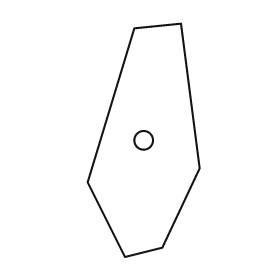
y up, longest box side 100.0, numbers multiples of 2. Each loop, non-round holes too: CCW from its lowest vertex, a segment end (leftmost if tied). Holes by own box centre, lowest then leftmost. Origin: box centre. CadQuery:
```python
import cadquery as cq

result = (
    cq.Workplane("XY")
    .moveTo(-8.0, -50.0)
    .lineTo(8.0, -46.0)
    .lineTo(24.0, -12.0)
    .lineTo(16.0, 50.0)
    .lineTo(-4.0, 48.0)
    .lineTo(-24.0, -18.0)
    .close()
    .moveTo(0.0, 0.0)
    .circle(4.0)
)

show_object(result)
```